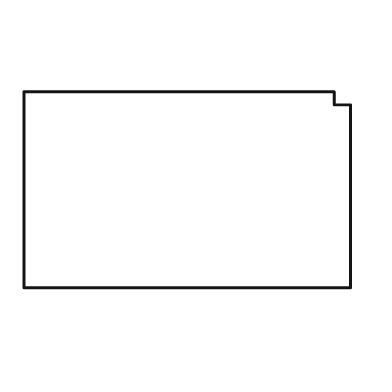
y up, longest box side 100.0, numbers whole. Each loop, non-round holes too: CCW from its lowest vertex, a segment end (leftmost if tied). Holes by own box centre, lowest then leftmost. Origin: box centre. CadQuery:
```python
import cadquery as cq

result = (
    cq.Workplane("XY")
    .moveTo(-50.0, -30.0)
    .lineTo(50.0, -30.0)
    .lineTo(50.0, 26.0)
    .lineTo(45.0, 26.0)
    .lineTo(45.0, 30.0)
    .lineTo(-50.0, 30.0)
    .close()
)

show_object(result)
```